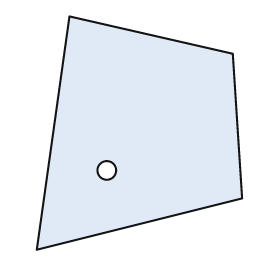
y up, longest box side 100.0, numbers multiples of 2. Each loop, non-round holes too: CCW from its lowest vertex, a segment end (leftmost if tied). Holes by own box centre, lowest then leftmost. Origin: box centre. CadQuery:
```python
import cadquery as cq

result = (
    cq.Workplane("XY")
    .moveTo(-44.0, -50.0)
    .lineTo(44.0, -28.0)
    .lineTo(40.0, 34.0)
    .lineTo(-30.0, 50.0)
    .close()
    .moveTo(-14.0, -16.0)
    .circle(4.0)
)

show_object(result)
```